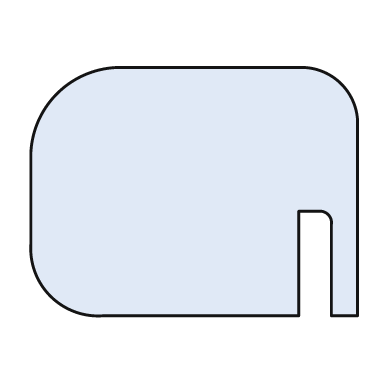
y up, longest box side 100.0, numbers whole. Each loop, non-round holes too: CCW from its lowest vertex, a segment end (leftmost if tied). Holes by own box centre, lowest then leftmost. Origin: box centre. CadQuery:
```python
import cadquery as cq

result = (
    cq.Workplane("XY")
    .moveTo(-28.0, -38.0)
    .lineTo(32.0, -38.0)
    .lineTo(32.0, -6.0)
    .lineTo(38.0, -6.0)
    .threePointArc((41.0, -7.0), (42.0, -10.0))
    .lineTo(42.0, -38.0)
    .lineTo(50.0, -38.0)
    .lineTo(50.0, 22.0)
    .threePointArc((45.0, 33.0), (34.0, 38.0))
    .lineTo(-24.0, 38.0)
    .threePointArc((-42.0, 30.0), (-50.0, 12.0))
    .lineTo(-50.0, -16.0)
    .threePointArc((-44.0, -32.0), (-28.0, -38.0))
    .close()
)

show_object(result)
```